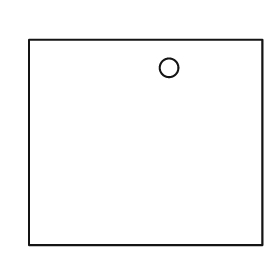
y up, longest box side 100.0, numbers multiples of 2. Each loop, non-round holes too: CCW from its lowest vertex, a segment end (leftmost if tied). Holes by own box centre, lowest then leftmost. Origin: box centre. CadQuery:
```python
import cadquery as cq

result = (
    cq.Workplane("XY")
    .moveTo(-50.0, -44.0)
    .lineTo(50.0, -44.0)
    .lineTo(50.0, 44.0)
    .lineTo(-50.0, 44.0)
    .close()
    .moveTo(10.0, 32.0)
    .circle(4.0)
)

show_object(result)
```